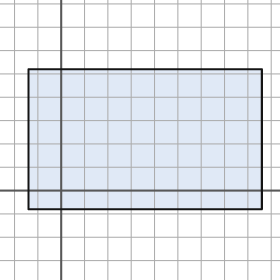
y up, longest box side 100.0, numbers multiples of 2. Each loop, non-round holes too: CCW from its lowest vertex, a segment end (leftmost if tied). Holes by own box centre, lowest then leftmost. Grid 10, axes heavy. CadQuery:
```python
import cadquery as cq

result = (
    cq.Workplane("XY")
    .moveTo(-14.0, -8.0)
    .lineTo(86.0, -8.0)
    .lineTo(86.0, 52.0)
    .lineTo(-14.0, 52.0)
    .close()
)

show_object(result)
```